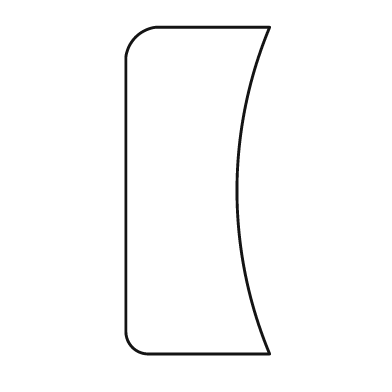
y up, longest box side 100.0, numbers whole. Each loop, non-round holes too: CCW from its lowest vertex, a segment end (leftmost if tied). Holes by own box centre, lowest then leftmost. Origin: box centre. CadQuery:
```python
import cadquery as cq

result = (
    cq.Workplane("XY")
    .moveTo(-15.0, -50.0)
    .lineTo(22.0, -50.0)
    .threePointArc((12.0, 0.0), (22.0, 50.0))
    .lineTo(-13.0, 50.0)
    .threePointArc((-19.0, 47.0), (-22.0, 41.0))
    .lineTo(-22.0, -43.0)
    .threePointArc((-20.0, -48.0), (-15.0, -50.0))
    .close()
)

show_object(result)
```